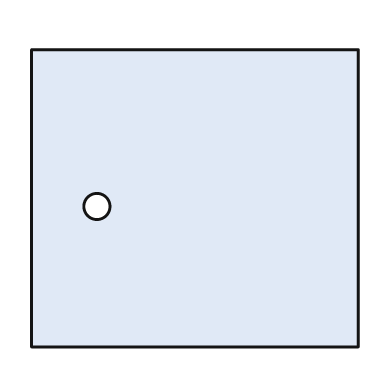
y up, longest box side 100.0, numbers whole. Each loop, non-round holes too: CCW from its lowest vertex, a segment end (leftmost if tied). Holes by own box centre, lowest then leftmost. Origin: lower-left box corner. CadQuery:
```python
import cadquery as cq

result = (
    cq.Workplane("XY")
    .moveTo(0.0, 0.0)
    .lineTo(100.0, 0.0)
    .lineTo(100.0, 91.0)
    .lineTo(0.0, 91.0)
    .close()
    .moveTo(20.0, 43.0)
    .circle(4.0)
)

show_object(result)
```